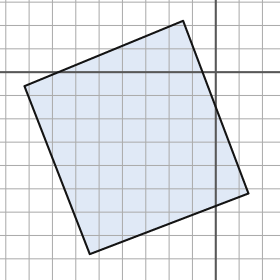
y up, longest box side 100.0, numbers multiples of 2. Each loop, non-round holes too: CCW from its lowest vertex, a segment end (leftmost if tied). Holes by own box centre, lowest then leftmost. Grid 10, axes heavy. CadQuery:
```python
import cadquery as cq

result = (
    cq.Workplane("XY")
    .moveTo(-54.0, -78.0)
    .lineTo(14.0, -52.0)
    .lineTo(-14.0, 22.0)
    .lineTo(-82.0, -6.0)
    .close()
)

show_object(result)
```